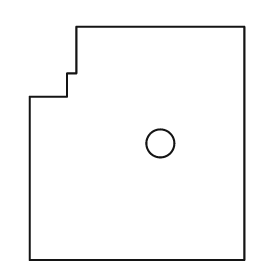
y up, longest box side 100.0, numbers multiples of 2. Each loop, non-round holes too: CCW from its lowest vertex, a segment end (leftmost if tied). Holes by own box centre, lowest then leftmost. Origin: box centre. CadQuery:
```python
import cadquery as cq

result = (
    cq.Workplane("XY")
    .moveTo(-46.0, -50.0)
    .lineTo(46.0, -50.0)
    .lineTo(46.0, 50.0)
    .lineTo(-26.0, 50.0)
    .lineTo(-26.0, 30.0)
    .lineTo(-30.0, 30.0)
    .lineTo(-30.0, 20.0)
    .lineTo(-46.0, 20.0)
    .close()
    .moveTo(10.0, 0.0)
    .circle(6.0)
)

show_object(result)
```